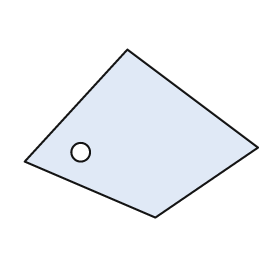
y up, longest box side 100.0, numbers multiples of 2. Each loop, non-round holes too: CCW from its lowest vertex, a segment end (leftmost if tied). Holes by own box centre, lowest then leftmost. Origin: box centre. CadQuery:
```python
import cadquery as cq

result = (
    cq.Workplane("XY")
    .moveTo(6.0, -36.0)
    .lineTo(50.0, -6.0)
    .lineTo(-6.0, 36.0)
    .lineTo(-50.0, -12.0)
    .close()
    .moveTo(-26.0, -8.0)
    .circle(4.0)
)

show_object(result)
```